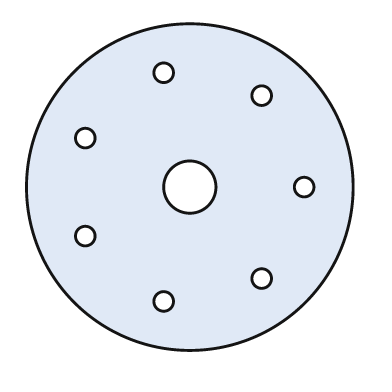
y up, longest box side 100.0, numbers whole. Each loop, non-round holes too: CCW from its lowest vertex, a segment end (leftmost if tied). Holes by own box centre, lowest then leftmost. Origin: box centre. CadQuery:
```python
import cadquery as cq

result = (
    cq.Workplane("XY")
    .moveTo(0.0, 0.0)
    .circle(50.0)
    .moveTo(-8.0, -35.0)
    .circle(3.0)
    .moveTo(22.0, -28.0)
    .circle(3.0)
    .moveTo(-32.0, -15.0)
    .circle(3.0)
    .moveTo(0.0, 0.0)
    .circle(8.0)
    .moveTo(35.0, 0.0)
    .circle(3.0)
    .moveTo(-32.0, 15.0)
    .circle(3.0)
    .moveTo(22.0, 28.0)
    .circle(3.0)
    .moveTo(-8.0, 35.0)
    .circle(3.0)
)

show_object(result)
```